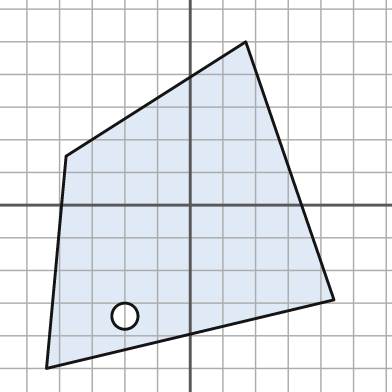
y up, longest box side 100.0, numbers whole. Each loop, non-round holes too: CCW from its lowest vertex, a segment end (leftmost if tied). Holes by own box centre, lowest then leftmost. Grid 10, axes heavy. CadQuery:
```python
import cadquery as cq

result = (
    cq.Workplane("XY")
    .moveTo(-44.0, -50.0)
    .lineTo(44.0, -29.0)
    .lineTo(17.0, 50.0)
    .lineTo(-38.0, 15.0)
    .close()
    .moveTo(-20.0, -34.0)
    .circle(4.0)
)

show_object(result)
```